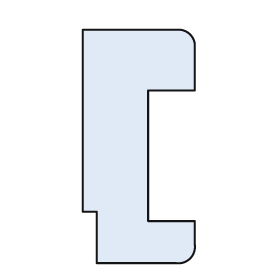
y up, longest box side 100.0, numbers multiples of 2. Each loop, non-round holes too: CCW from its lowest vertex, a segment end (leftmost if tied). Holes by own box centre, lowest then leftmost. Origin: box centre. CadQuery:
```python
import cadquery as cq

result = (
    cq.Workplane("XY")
    .moveTo(-18.0, -50.0)
    .lineTo(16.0, -50.0)
    .threePointArc((22.0, -48.0), (24.0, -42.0))
    .lineTo(24.0, -32.0)
    .lineTo(4.0, -32.0)
    .lineTo(4.0, 24.0)
    .lineTo(24.0, 24.0)
    .lineTo(24.0, 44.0)
    .threePointArc((22.0, 48.0), (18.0, 50.0))
    .lineTo(-24.0, 50.0)
    .lineTo(-24.0, -28.0)
    .lineTo(-18.0, -28.0)
    .close()
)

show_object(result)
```